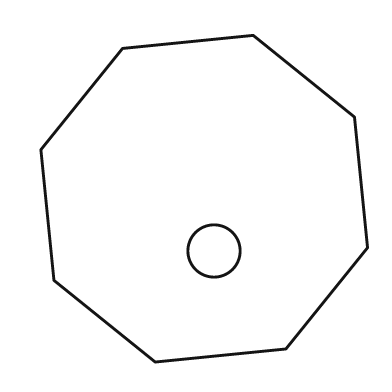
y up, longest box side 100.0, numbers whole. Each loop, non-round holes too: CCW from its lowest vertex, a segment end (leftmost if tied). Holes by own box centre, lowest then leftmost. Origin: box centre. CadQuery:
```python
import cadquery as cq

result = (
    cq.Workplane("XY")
    .moveTo(-15.0, -50.0)
    .lineTo(25.0, -46.0)
    .lineTo(50.0, -15.0)
    .lineTo(46.0, 25.0)
    .lineTo(15.0, 50.0)
    .lineTo(-25.0, 46.0)
    .lineTo(-50.0, 15.0)
    .lineTo(-46.0, -25.0)
    .close()
    .moveTo(3.0, -16.0)
    .circle(8.0)
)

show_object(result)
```